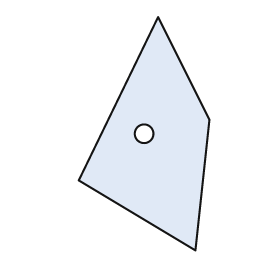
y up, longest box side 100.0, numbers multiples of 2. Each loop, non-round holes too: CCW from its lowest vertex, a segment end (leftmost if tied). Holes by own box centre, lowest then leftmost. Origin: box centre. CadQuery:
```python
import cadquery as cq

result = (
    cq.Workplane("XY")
    .moveTo(22.0, -50.0)
    .lineTo(28.0, 6.0)
    .lineTo(6.0, 50.0)
    .lineTo(-28.0, -20.0)
    .close()
    .moveTo(0.0, 0.0)
    .circle(4.0)
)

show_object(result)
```